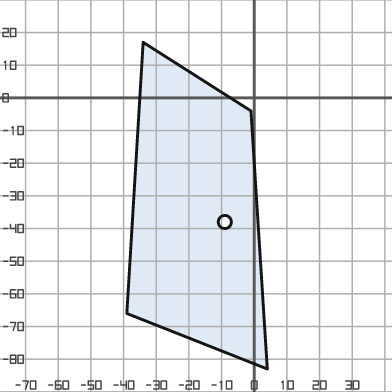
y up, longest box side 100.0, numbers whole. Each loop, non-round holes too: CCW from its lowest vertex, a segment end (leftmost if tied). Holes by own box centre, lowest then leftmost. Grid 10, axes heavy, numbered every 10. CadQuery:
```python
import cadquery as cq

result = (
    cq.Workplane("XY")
    .moveTo(4.0, -83.0)
    .lineTo(-1.0, -4.0)
    .lineTo(-34.0, 17.0)
    .lineTo(-39.0, -66.0)
    .close()
    .moveTo(-9.0, -38.0)
    .circle(2.0)
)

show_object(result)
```